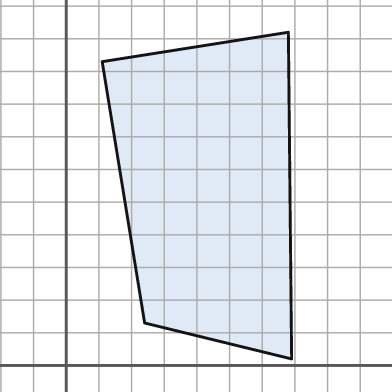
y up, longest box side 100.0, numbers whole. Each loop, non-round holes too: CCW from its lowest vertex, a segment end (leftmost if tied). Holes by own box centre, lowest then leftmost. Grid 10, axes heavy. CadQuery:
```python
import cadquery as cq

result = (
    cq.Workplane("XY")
    .moveTo(69.0, 2.0)
    .lineTo(68.0, 102.0)
    .lineTo(11.0, 93.0)
    .lineTo(24.0, 13.0)
    .close()
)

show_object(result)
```